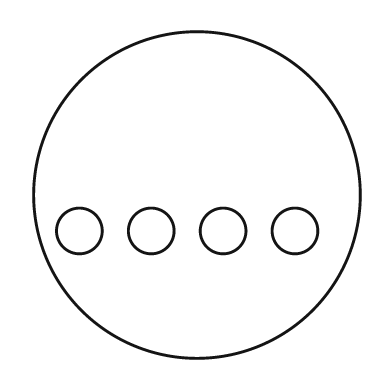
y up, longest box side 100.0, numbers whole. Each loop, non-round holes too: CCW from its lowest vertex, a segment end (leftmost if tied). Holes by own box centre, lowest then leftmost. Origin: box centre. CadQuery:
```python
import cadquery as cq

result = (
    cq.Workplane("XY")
    .moveTo(0.0, 0.0)
    .circle(50.0)
    .moveTo(-36.0, -11.0)
    .circle(7.0)
    .moveTo(-14.0, -11.0)
    .circle(7.0)
    .moveTo(8.0, -11.0)
    .circle(7.0)
    .moveTo(30.0, -11.0)
    .circle(7.0)
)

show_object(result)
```